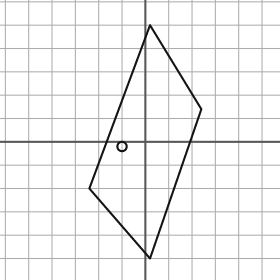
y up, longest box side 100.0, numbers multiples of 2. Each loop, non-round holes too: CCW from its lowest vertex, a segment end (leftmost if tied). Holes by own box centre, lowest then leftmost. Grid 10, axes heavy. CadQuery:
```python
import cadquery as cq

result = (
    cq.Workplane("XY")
    .moveTo(2.0, -50.0)
    .lineTo(24.0, 14.0)
    .lineTo(2.0, 50.0)
    .lineTo(-24.0, -20.0)
    .close()
    .moveTo(-10.0, -2.0)
    .circle(2.0)
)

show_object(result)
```